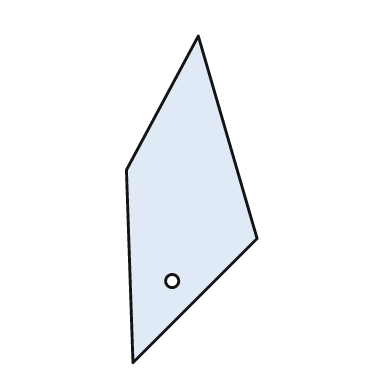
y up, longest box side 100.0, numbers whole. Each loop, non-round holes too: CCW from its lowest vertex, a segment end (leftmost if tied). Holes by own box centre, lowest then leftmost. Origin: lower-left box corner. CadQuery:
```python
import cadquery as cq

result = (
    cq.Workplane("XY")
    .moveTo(2.0, 0.0)
    .lineTo(40.0, 38.0)
    .lineTo(22.0, 100.0)
    .lineTo(0.0, 59.0)
    .close()
    .moveTo(14.0, 25.0)
    .circle(2.0)
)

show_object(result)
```